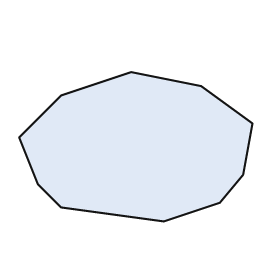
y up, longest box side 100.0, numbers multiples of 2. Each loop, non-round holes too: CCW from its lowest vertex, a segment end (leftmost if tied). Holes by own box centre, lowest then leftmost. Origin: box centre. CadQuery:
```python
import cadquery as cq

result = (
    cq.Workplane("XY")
    .moveTo(12.0, -32.0)
    .lineTo(36.0, -24.0)
    .lineTo(46.0, -12.0)
    .lineTo(50.0, 10.0)
    .lineTo(28.0, 26.0)
    .lineTo(-2.0, 32.0)
    .lineTo(-32.0, 22.0)
    .lineTo(-50.0, 4.0)
    .lineTo(-42.0, -16.0)
    .lineTo(-32.0, -26.0)
    .close()
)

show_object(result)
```